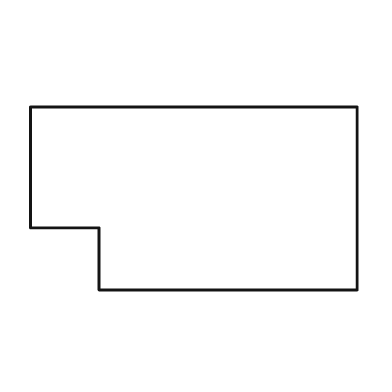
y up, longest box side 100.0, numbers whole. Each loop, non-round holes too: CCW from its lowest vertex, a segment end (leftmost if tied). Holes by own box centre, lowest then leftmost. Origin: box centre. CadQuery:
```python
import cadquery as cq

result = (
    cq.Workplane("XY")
    .moveTo(-29.0, -28.0)
    .lineTo(50.0, -28.0)
    .lineTo(50.0, 28.0)
    .lineTo(-50.0, 28.0)
    .lineTo(-50.0, -9.0)
    .lineTo(-29.0, -9.0)
    .close()
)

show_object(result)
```